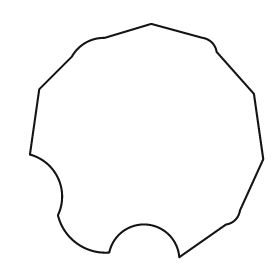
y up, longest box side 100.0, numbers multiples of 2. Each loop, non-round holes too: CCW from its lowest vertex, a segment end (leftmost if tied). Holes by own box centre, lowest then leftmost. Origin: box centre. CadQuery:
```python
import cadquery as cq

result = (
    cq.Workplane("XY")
    .moveTo(14.0, -50.0)
    .lineTo(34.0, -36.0)
    .threePointArc((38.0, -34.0), (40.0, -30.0))
    .lineTo(50.0, -8.0)
    .lineTo(46.0, 20.0)
    .lineTo(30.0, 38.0)
    .threePointArc((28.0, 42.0), (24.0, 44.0))
    .lineTo(2.0, 50.0)
    .lineTo(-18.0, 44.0)
    .threePointArc((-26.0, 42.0), (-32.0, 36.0))
    .lineTo(-46.0, 22.0)
    .lineTo(-50.0, -6.0)
    .threePointArc((-38.0, -16.0), (-38.0, -32.0))
    .threePointArc((-30.0, -44.0), (-16.0, -48.0))
    .threePointArc((0.0, -36.0), (14.0, -50.0))
    .close()
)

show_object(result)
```